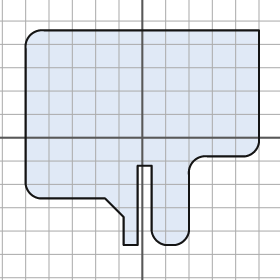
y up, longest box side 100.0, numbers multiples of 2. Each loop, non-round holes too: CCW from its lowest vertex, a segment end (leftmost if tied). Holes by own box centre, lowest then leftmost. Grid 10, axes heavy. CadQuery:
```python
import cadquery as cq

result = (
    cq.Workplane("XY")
    .moveTo(-8.0, -46.0)
    .lineTo(-2.0, -46.0)
    .lineTo(-2.0, -12.0)
    .lineTo(4.0, -12.0)
    .lineTo(4.0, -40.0)
    .threePointArc((6.0, -44.0), (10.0, -46.0))
    .lineTo(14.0, -46.0)
    .threePointArc((18.0, -44.0), (20.0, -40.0))
    .lineTo(20.0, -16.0)
    .threePointArc((22.0, -10.0), (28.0, -8.0))
    .lineTo(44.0, -8.0)
    .threePointArc((48.0, -6.0), (50.0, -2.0))
    .lineTo(50.0, 46.0)
    .lineTo(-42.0, 46.0)
    .threePointArc((-48.0, 44.0), (-50.0, 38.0))
    .lineTo(-50.0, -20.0)
    .threePointArc((-48.0, -24.0), (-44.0, -26.0))
    .lineTo(-16.0, -26.0)
    .lineTo(-8.0, -34.0)
    .close()
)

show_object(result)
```